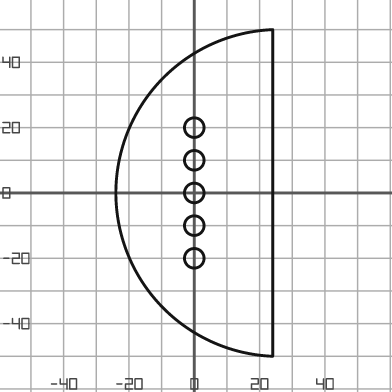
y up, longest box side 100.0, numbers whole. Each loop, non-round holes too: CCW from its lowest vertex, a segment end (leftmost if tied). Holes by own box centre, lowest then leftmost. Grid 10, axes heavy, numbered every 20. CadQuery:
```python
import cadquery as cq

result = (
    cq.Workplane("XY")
    .moveTo(24.0, -50.0)
    .lineTo(24.0, 50.0)
    .threePointArc((-24.0, 0.0), (24.0, -50.0))
    .close()
    .moveTo(0.0, -20.0)
    .circle(3.0)
    .moveTo(0.0, -10.0)
    .circle(3.0)
    .moveTo(0.0, 0.0)
    .circle(3.0)
    .moveTo(0.0, 10.0)
    .circle(3.0)
    .moveTo(0.0, 20.0)
    .circle(3.0)
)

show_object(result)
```